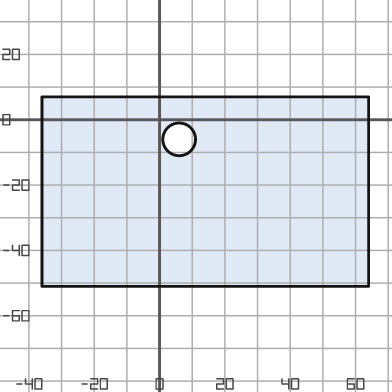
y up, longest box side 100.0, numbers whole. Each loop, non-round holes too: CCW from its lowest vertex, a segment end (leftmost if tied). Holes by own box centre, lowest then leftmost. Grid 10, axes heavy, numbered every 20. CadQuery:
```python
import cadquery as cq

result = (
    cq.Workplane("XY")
    .moveTo(-36.0, -51.0)
    .lineTo(64.0, -51.0)
    .lineTo(64.0, 7.0)
    .lineTo(-36.0, 7.0)
    .close()
    .moveTo(6.0, -6.0)
    .circle(5.0)
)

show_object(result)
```